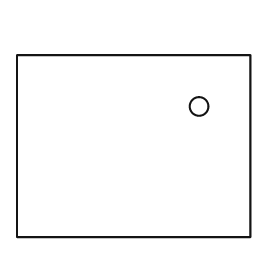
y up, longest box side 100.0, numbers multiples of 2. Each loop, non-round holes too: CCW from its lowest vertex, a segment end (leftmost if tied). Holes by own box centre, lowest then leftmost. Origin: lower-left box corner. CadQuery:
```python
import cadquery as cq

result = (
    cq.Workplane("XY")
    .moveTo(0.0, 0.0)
    .lineTo(100.0, 0.0)
    .lineTo(100.0, 78.0)
    .lineTo(0.0, 78.0)
    .close()
    .moveTo(78.0, 56.0)
    .circle(4.0)
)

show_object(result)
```